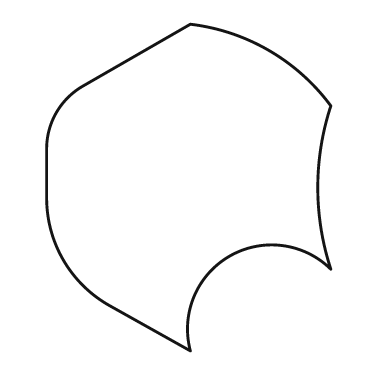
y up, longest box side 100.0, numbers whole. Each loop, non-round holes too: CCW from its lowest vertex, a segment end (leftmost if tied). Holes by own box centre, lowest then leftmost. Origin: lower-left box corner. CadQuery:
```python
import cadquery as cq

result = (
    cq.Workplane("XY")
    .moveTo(44.0, 0.0)
    .threePointArc((56.0, 29.0), (87.0, 25.0))
    .threePointArc((83.0, 50.0), (87.0, 75.0))
    .threePointArc((68.0, 92.0), (44.0, 100.0))
    .lineTo(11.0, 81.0)
    .threePointArc((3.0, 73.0), (0.0, 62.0))
    .lineTo(0.0, 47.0)
    .threePointArc((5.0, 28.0), (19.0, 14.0))
    .close()
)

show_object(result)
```